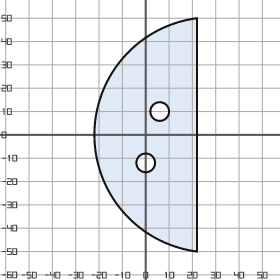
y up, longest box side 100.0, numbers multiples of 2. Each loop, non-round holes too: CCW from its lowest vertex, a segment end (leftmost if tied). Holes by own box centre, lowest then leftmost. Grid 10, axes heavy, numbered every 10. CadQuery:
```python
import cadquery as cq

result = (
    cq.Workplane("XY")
    .moveTo(22.0, -50.0)
    .lineTo(22.0, 50.0)
    .threePointArc((-22.0, 0.0), (22.0, -50.0))
    .close()
    .moveTo(0.0, -12.0)
    .circle(4.0)
    .moveTo(6.0, 10.0)
    .circle(4.0)
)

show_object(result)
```